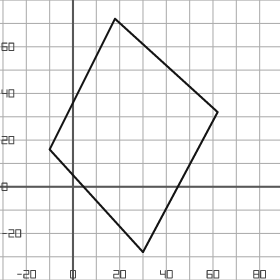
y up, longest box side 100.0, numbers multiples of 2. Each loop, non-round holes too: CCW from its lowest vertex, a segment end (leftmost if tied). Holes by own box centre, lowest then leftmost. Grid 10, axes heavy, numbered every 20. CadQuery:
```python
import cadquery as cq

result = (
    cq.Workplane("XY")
    .moveTo(30.0, -28.0)
    .lineTo(62.0, 32.0)
    .lineTo(18.0, 72.0)
    .lineTo(-10.0, 16.0)
    .close()
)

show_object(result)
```